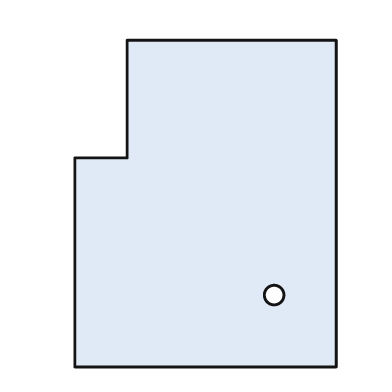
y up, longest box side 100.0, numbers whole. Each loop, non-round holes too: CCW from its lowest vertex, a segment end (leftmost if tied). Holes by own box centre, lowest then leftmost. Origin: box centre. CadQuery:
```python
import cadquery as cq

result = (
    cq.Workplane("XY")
    .moveTo(-40.0, -50.0)
    .lineTo(40.0, -50.0)
    .lineTo(40.0, 50.0)
    .lineTo(-24.0, 50.0)
    .lineTo(-24.0, 14.0)
    .lineTo(-40.0, 14.0)
    .close()
    .moveTo(21.0, -28.0)
    .circle(3.0)
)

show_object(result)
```